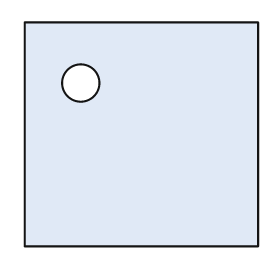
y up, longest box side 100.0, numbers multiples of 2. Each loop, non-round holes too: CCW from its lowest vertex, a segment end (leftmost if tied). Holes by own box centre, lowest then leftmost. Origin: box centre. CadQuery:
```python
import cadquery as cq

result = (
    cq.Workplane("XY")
    .moveTo(-50.0, -48.0)
    .lineTo(50.0, -48.0)
    .lineTo(50.0, 48.0)
    .lineTo(-50.0, 48.0)
    .close()
    .moveTo(-26.0, 22.0)
    .circle(8.0)
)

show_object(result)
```